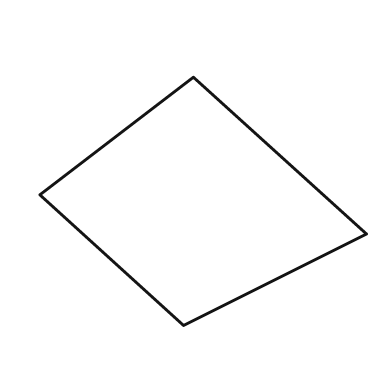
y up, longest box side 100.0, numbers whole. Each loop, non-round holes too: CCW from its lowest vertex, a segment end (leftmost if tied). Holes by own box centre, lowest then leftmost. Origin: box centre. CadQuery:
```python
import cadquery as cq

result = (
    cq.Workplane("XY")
    .moveTo(-6.0, -38.0)
    .lineTo(50.0, -10.0)
    .lineTo(-3.0, 38.0)
    .lineTo(-50.0, 2.0)
    .close()
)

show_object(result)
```